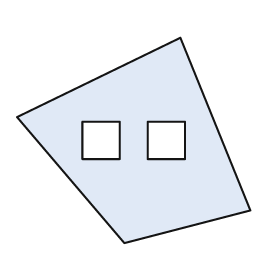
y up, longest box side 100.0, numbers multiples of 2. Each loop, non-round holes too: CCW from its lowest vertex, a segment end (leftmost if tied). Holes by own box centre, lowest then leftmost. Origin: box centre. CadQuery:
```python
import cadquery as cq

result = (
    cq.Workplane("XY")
    .moveTo(-4.0, -44.0)
    .lineTo(50.0, -30.0)
    .lineTo(20.0, 44.0)
    .lineTo(-50.0, 10.0)
    .close()
    .moveTo(-22.0, -8.0)
    .lineTo(-6.0, -8.0)
    .lineTo(-6.0, 8.0)
    .lineTo(-22.0, 8.0)
    .close()
    .moveTo(6.0, -8.0)
    .lineTo(22.0, -8.0)
    .lineTo(22.0, 8.0)
    .lineTo(6.0, 8.0)
    .close()
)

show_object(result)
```